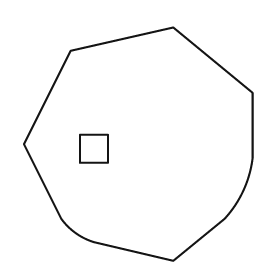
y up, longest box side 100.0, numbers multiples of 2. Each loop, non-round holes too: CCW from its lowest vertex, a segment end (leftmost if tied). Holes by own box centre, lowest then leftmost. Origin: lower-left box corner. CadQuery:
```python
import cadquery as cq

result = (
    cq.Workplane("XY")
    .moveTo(64.0, 0.0)
    .lineTo(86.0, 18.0)
    .threePointArc((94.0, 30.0), (98.0, 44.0))
    .lineTo(98.0, 72.0)
    .lineTo(64.0, 100.0)
    .lineTo(20.0, 90.0)
    .lineTo(0.0, 50.0)
    .lineTo(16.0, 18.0)
    .threePointArc((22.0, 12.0), (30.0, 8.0))
    .close()
    .moveTo(24.0, 42.0)
    .lineTo(36.0, 42.0)
    .lineTo(36.0, 54.0)
    .lineTo(24.0, 54.0)
    .close()
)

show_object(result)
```